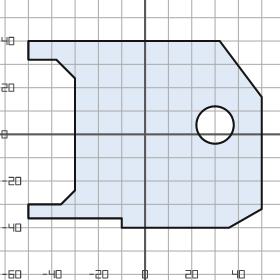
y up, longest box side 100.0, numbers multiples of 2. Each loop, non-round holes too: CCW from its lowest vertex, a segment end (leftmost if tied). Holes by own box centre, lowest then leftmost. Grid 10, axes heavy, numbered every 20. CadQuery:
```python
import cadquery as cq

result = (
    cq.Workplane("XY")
    .moveTo(-10.0, -40.0)
    .lineTo(36.0, -40.0)
    .lineTo(50.0, -32.0)
    .lineTo(50.0, 16.0)
    .lineTo(32.0, 40.0)
    .lineTo(-50.0, 40.0)
    .lineTo(-50.0, 32.0)
    .lineTo(-38.0, 32.0)
    .lineTo(-30.0, 24.0)
    .lineTo(-30.0, -24.0)
    .lineTo(-36.0, -30.0)
    .lineTo(-50.0, -30.0)
    .lineTo(-50.0, -36.0)
    .lineTo(-10.0, -36.0)
    .close()
    .moveTo(30.0, 4.0)
    .circle(8.0)
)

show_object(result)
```